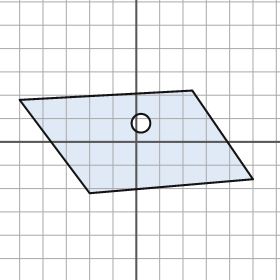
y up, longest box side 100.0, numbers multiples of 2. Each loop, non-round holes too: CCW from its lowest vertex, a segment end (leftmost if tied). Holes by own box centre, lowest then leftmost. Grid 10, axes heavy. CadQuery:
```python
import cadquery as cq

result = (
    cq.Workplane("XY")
    .moveTo(-20.0, -22.0)
    .lineTo(50.0, -16.0)
    .lineTo(24.0, 22.0)
    .lineTo(-50.0, 18.0)
    .close()
    .moveTo(2.0, 8.0)
    .circle(4.0)
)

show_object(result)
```